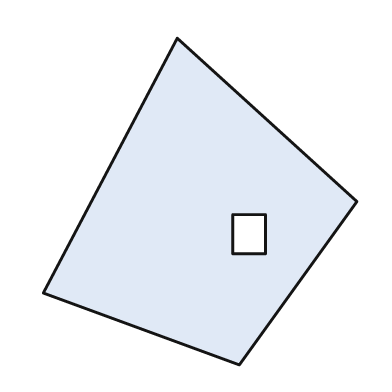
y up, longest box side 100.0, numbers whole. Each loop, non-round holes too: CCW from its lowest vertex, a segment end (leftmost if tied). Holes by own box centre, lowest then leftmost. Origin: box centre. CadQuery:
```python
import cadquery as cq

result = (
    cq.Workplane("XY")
    .moveTo(12.0, -50.0)
    .lineTo(48.0, 0.0)
    .lineTo(-7.0, 50.0)
    .lineTo(-48.0, -28.0)
    .close()
    .moveTo(10.0, -16.0)
    .lineTo(20.0, -16.0)
    .lineTo(20.0, -4.0)
    .lineTo(10.0, -4.0)
    .close()
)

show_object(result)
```